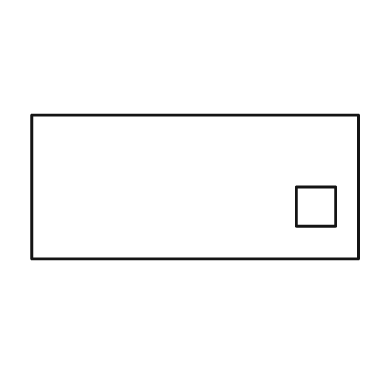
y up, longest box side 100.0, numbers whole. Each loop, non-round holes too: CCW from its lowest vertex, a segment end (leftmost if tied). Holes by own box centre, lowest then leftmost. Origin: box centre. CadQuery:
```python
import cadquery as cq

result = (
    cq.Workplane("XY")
    .moveTo(-50.0, -22.0)
    .lineTo(50.0, -22.0)
    .lineTo(50.0, 22.0)
    .lineTo(-50.0, 22.0)
    .close()
    .moveTo(31.0, -12.0)
    .lineTo(43.0, -12.0)
    .lineTo(43.0, 0.0)
    .lineTo(31.0, 0.0)
    .close()
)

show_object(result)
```